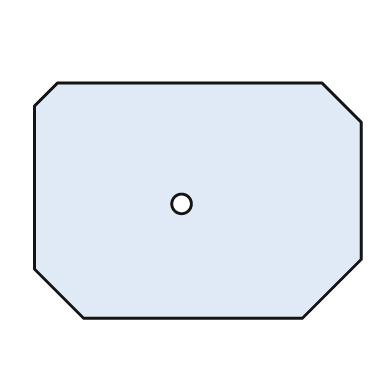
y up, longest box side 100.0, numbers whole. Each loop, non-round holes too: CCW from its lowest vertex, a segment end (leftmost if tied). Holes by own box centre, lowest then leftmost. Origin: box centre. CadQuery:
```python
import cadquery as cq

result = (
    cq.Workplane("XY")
    .moveTo(-35.0, -36.0)
    .lineTo(32.0, -36.0)
    .lineTo(50.0, -18.0)
    .lineTo(50.0, 24.0)
    .lineTo(38.0, 36.0)
    .lineTo(-43.0, 36.0)
    .lineTo(-50.0, 29.0)
    .lineTo(-50.0, -21.0)
    .close()
    .moveTo(-5.0, -1.0)
    .circle(3.0)
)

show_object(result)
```